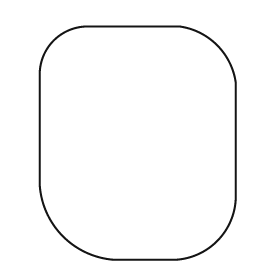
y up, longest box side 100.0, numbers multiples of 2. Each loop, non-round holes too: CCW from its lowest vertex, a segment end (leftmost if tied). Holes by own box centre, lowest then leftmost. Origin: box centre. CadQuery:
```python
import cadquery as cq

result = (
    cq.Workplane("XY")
    .moveTo(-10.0, -50.0)
    .lineTo(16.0, -50.0)
    .threePointArc((34.0, -42.0), (42.0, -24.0))
    .lineTo(42.0, 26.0)
    .threePointArc((34.0, 42.0), (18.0, 50.0))
    .lineTo(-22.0, 50.0)
    .threePointArc((-36.0, 44.0), (-42.0, 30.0))
    .lineTo(-42.0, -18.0)
    .threePointArc((-32.0, -40.0), (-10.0, -50.0))
    .close()
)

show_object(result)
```